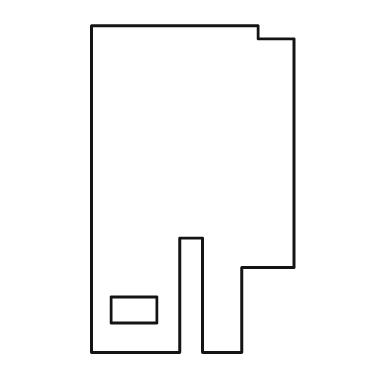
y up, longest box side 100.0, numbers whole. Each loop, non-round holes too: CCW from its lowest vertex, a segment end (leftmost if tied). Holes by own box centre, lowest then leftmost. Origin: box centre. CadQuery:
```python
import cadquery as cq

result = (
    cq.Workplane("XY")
    .moveTo(-31.0, -50.0)
    .lineTo(-4.0, -50.0)
    .lineTo(-4.0, -15.0)
    .lineTo(3.0, -15.0)
    .lineTo(3.0, -50.0)
    .lineTo(15.0, -50.0)
    .lineTo(15.0, -24.0)
    .lineTo(31.0, -24.0)
    .lineTo(31.0, 46.0)
    .lineTo(20.0, 46.0)
    .lineTo(20.0, 50.0)
    .lineTo(-31.0, 50.0)
    .close()
    .moveTo(-25.0, -41.0)
    .lineTo(-11.0, -41.0)
    .lineTo(-11.0, -33.0)
    .lineTo(-25.0, -33.0)
    .close()
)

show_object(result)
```